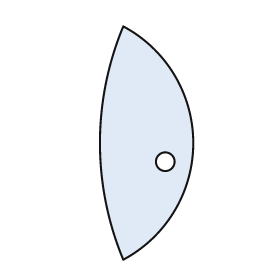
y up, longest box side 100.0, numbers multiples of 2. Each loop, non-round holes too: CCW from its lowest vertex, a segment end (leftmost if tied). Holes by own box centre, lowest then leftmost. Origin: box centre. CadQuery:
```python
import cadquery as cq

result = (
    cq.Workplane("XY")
    .moveTo(-10.0, -50.0)
    .threePointArc((20.0, 0.0), (-10.0, 50.0))
    .threePointArc((-20.0, 0.0), (-10.0, -50.0))
    .close()
    .moveTo(8.0, -8.0)
    .circle(4.0)
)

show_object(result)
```